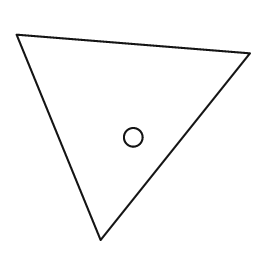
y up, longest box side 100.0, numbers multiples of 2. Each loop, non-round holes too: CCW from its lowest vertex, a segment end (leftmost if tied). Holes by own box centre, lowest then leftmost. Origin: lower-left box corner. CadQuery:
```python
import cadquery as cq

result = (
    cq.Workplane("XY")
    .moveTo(36.0, 0.0)
    .lineTo(100.0, 80.0)
    .lineTo(0.0, 88.0)
    .close()
    .moveTo(50.0, 44.0)
    .circle(4.0)
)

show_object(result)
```